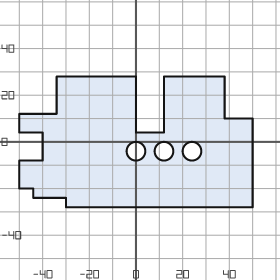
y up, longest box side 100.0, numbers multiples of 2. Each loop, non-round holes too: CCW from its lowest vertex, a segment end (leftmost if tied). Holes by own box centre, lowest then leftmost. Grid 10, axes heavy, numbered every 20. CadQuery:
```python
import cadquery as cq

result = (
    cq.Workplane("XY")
    .moveTo(-30.0, -28.0)
    .lineTo(50.0, -28.0)
    .lineTo(50.0, 10.0)
    .lineTo(38.0, 10.0)
    .lineTo(38.0, 28.0)
    .lineTo(12.0, 28.0)
    .lineTo(12.0, 4.0)
    .lineTo(0.0, 4.0)
    .lineTo(0.0, 28.0)
    .lineTo(-34.0, 28.0)
    .lineTo(-34.0, 12.0)
    .lineTo(-50.0, 12.0)
    .lineTo(-50.0, 4.0)
    .lineTo(-40.0, 4.0)
    .lineTo(-40.0, -8.0)
    .lineTo(-50.0, -8.0)
    .lineTo(-50.0, -20.0)
    .lineTo(-44.0, -20.0)
    .lineTo(-44.0, -24.0)
    .lineTo(-30.0, -24.0)
    .close()
    .moveTo(0.0, -4.0)
    .circle(4.0)
    .moveTo(12.0, -4.0)
    .circle(4.0)
    .moveTo(24.0, -4.0)
    .circle(4.0)
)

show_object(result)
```